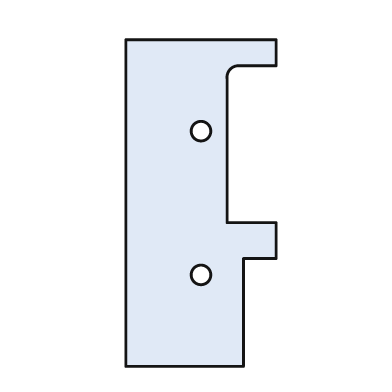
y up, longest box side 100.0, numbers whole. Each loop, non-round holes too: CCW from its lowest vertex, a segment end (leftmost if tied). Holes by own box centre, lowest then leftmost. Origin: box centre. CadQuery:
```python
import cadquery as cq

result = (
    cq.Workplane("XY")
    .moveTo(-23.0, -50.0)
    .lineTo(13.0, -50.0)
    .lineTo(13.0, -17.0)
    .lineTo(23.0, -17.0)
    .lineTo(23.0, -6.0)
    .lineTo(8.0, -6.0)
    .lineTo(8.0, 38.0)
    .threePointArc((9.0, 41.0), (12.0, 42.0))
    .lineTo(23.0, 42.0)
    .lineTo(23.0, 50.0)
    .lineTo(-23.0, 50.0)
    .close()
    .moveTo(0.0, -22.0)
    .circle(3.0)
    .moveTo(0.0, 22.0)
    .circle(3.0)
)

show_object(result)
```